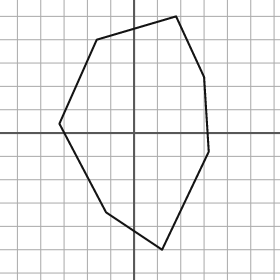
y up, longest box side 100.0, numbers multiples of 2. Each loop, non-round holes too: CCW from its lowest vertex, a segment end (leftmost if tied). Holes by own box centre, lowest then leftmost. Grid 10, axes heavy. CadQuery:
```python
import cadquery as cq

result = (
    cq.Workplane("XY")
    .moveTo(12.0, -50.0)
    .lineTo(32.0, -8.0)
    .lineTo(30.0, 24.0)
    .lineTo(18.0, 50.0)
    .lineTo(-16.0, 40.0)
    .lineTo(-32.0, 4.0)
    .lineTo(-12.0, -34.0)
    .close()
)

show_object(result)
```